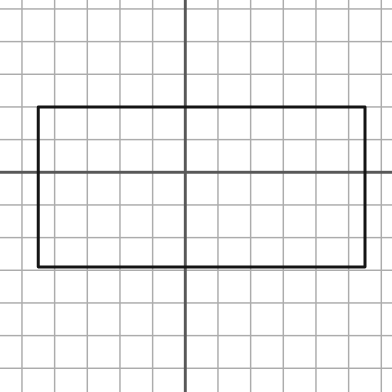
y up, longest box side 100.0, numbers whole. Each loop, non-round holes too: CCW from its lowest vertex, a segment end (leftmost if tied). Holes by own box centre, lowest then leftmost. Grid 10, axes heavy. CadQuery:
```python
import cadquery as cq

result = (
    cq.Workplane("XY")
    .moveTo(-45.0, -29.0)
    .lineTo(55.0, -29.0)
    .lineTo(55.0, 20.0)
    .lineTo(-45.0, 20.0)
    .close()
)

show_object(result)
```